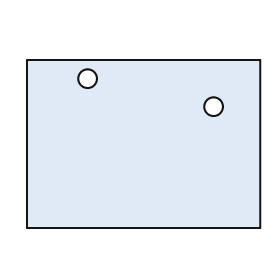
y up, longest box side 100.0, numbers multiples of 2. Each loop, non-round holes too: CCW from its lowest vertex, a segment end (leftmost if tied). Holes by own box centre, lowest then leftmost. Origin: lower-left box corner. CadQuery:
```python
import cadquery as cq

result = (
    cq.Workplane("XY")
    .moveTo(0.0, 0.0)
    .lineTo(100.0, 0.0)
    .lineTo(100.0, 72.0)
    .lineTo(0.0, 72.0)
    .close()
    .moveTo(80.0, 52.0)
    .circle(4.0)
    .moveTo(26.0, 64.0)
    .circle(4.0)
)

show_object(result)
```